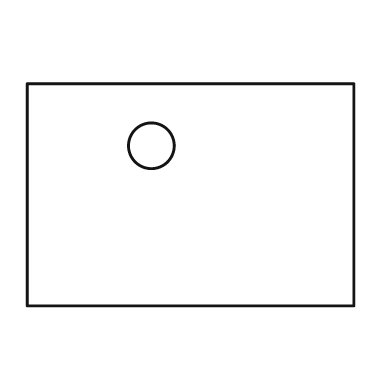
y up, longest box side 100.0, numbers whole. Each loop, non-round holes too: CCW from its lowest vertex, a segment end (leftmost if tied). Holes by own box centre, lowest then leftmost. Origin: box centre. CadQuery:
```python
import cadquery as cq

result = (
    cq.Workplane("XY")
    .moveTo(-50.0, -34.0)
    .lineTo(50.0, -34.0)
    .lineTo(50.0, 34.0)
    .lineTo(-50.0, 34.0)
    .close()
    .moveTo(-12.0, 15.0)
    .circle(7.0)
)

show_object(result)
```